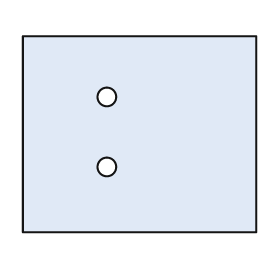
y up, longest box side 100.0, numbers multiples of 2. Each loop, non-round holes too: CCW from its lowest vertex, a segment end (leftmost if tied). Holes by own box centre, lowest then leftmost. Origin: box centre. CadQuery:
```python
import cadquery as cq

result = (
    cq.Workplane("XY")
    .moveTo(-50.0, -42.0)
    .lineTo(50.0, -42.0)
    .lineTo(50.0, 42.0)
    .lineTo(-50.0, 42.0)
    .close()
    .moveTo(-14.0, -14.0)
    .circle(4.0)
    .moveTo(-14.0, 16.0)
    .circle(4.0)
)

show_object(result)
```